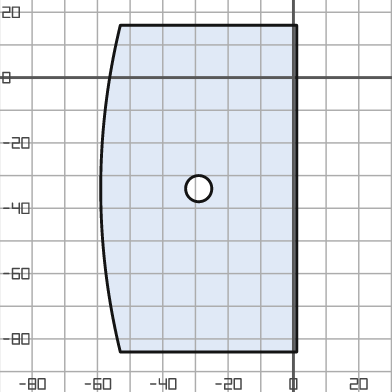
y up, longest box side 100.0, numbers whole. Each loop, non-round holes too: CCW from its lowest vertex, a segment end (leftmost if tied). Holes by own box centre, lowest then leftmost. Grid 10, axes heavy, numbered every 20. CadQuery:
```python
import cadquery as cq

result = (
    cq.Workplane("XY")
    .moveTo(-53.0, -84.0)
    .lineTo(1.0, -84.0)
    .lineTo(1.0, 16.0)
    .lineTo(-53.0, 16.0)
    .threePointArc((-59.0, -34.0), (-53.0, -84.0))
    .close()
    .moveTo(-29.0, -34.0)
    .circle(4.0)
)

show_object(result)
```